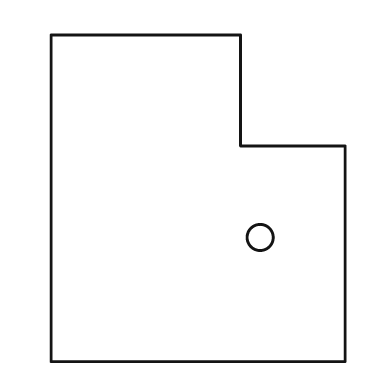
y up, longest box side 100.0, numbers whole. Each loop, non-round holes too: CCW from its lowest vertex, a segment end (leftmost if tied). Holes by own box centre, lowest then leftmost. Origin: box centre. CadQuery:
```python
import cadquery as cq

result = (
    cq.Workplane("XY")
    .moveTo(-45.0, -50.0)
    .lineTo(45.0, -50.0)
    .lineTo(45.0, 16.0)
    .lineTo(13.0, 16.0)
    .lineTo(13.0, 50.0)
    .lineTo(-45.0, 50.0)
    .close()
    .moveTo(19.0, -12.0)
    .circle(4.0)
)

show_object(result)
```